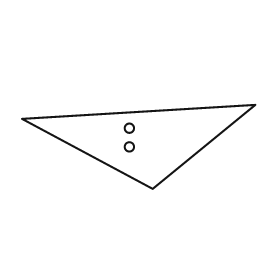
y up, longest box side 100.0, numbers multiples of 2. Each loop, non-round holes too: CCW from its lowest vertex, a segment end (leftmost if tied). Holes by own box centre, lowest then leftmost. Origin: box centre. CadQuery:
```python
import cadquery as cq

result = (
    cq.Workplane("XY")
    .moveTo(6.0, -18.0)
    .lineTo(50.0, 18.0)
    .lineTo(-50.0, 12.0)
    .close()
    .moveTo(-4.0, 0.0)
    .circle(2.0)
    .moveTo(-4.0, 8.0)
    .circle(2.0)
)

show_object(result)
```